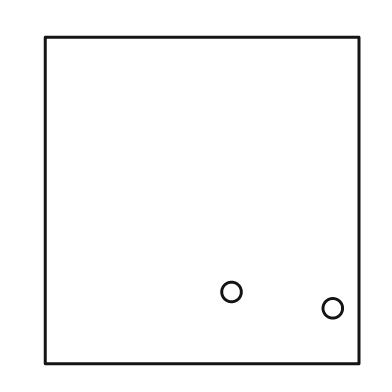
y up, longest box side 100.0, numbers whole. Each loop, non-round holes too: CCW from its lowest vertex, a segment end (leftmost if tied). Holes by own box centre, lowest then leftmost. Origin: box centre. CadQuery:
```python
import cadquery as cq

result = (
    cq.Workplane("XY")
    .moveTo(-48.0, -50.0)
    .lineTo(48.0, -50.0)
    .lineTo(48.0, 50.0)
    .lineTo(-48.0, 50.0)
    .close()
    .moveTo(40.0, -33.0)
    .circle(3.0)
    .moveTo(9.0, -28.0)
    .circle(3.0)
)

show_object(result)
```